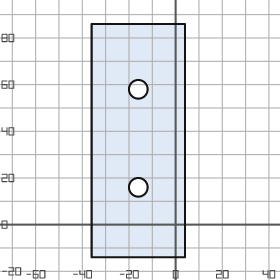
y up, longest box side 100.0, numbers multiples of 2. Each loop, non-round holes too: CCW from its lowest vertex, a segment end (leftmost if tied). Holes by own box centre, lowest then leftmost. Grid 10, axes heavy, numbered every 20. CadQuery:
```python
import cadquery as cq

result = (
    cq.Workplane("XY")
    .moveTo(-36.0, -14.0)
    .lineTo(4.0, -14.0)
    .lineTo(4.0, 86.0)
    .lineTo(-36.0, 86.0)
    .close()
    .moveTo(-16.0, 16.0)
    .circle(4.0)
    .moveTo(-16.0, 58.0)
    .circle(4.0)
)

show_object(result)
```